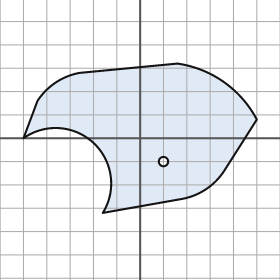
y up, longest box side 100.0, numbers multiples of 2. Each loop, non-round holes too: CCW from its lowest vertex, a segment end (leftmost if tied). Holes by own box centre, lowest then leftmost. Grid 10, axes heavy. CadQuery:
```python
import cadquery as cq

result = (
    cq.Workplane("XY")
    .moveTo(-16.0, -32.0)
    .lineTo(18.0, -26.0)
    .threePointArc((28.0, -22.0), (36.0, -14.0))
    .lineTo(50.0, 8.0)
    .threePointArc((36.0, 24.0), (16.0, 32.0))
    .lineTo(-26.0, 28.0)
    .threePointArc((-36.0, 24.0), (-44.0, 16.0))
    .lineTo(-50.0, 0.0)
    .threePointArc((-20.0, -2.0), (-16.0, -32.0))
    .close()
    .moveTo(10.0, -10.0)
    .circle(2.0)
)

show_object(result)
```